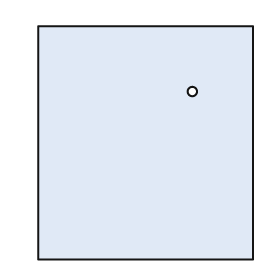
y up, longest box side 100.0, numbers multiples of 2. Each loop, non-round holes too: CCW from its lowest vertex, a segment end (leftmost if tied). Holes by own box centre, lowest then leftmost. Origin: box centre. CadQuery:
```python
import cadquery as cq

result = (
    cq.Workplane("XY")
    .moveTo(-46.0, -50.0)
    .lineTo(46.0, -50.0)
    .lineTo(46.0, 50.0)
    .lineTo(-46.0, 50.0)
    .close()
    .moveTo(20.0, 22.0)
    .circle(2.0)
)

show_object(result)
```